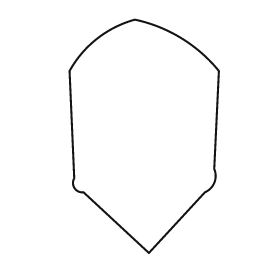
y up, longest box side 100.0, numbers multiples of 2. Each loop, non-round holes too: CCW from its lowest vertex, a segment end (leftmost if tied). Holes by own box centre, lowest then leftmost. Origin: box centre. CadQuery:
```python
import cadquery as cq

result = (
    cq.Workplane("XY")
    .moveTo(2.0, -50.0)
    .lineTo(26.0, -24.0)
    .threePointArc((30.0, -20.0), (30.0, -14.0))
    .lineTo(32.0, 28.0)
    .threePointArc((16.0, 42.0), (-4.0, 50.0))
    .threePointArc((-20.0, 42.0), (-32.0, 28.0))
    .lineTo(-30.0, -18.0)
    .threePointArc((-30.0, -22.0), (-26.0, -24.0))
    .close()
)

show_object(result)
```